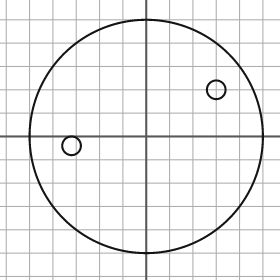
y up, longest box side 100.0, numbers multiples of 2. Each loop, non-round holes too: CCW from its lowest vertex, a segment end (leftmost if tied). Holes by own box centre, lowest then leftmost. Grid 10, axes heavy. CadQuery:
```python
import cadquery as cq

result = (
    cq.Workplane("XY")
    .moveTo(0.0, 0.0)
    .circle(50.0)
    .moveTo(-32.0, -4.0)
    .circle(4.0)
    .moveTo(30.0, 20.0)
    .circle(4.0)
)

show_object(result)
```